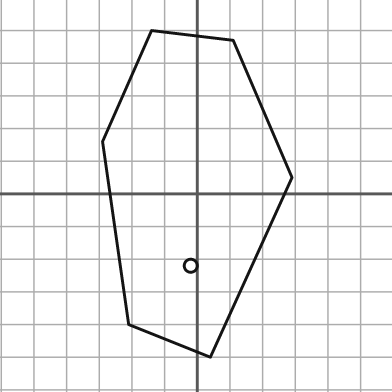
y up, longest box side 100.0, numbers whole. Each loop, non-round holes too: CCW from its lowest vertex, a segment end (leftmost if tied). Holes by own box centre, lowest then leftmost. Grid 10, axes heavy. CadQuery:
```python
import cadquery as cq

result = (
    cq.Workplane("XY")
    .moveTo(4.0, -50.0)
    .lineTo(29.0, 5.0)
    .lineTo(11.0, 47.0)
    .lineTo(-14.0, 50.0)
    .lineTo(-29.0, 16.0)
    .lineTo(-21.0, -40.0)
    .close()
    .moveTo(-2.0, -22.0)
    .circle(2.0)
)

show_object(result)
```